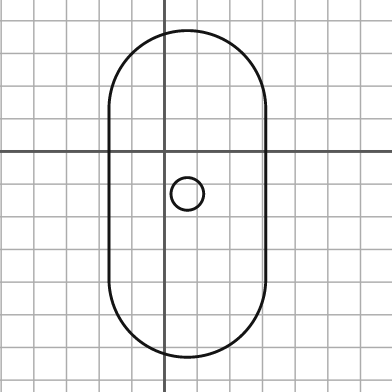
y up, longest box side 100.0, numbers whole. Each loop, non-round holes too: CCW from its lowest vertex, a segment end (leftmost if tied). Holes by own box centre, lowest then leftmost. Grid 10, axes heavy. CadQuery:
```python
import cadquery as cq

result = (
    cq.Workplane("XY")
    .moveTo(-17.0, -39.0)
    .threePointArc((7.0, -63.0), (31.0, -39.0))
    .lineTo(31.0, 13.0)
    .threePointArc((7.0, 37.0), (-17.0, 13.0))
    .close()
    .moveTo(7.0, -13.0)
    .circle(5.0)
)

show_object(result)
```